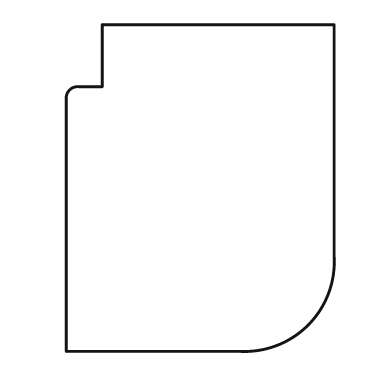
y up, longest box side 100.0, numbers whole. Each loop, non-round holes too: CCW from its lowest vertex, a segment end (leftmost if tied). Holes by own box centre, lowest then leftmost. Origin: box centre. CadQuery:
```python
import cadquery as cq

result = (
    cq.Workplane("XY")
    .moveTo(-41.0, -50.0)
    .lineTo(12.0, -50.0)
    .threePointArc((33.0, -42.0), (41.0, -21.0))
    .lineTo(41.0, 50.0)
    .lineTo(-30.0, 50.0)
    .lineTo(-30.0, 31.0)
    .lineTo(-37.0, 31.0)
    .threePointArc((-40.0, 30.0), (-41.0, 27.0))
    .close()
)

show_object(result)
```